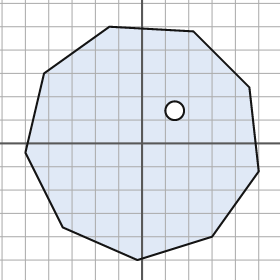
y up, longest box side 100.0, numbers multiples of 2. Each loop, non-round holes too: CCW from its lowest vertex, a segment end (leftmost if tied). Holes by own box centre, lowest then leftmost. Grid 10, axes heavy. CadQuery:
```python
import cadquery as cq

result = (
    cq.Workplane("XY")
    .moveTo(-2.0, -50.0)
    .lineTo(30.0, -40.0)
    .lineTo(50.0, -12.0)
    .lineTo(46.0, 24.0)
    .lineTo(22.0, 48.0)
    .lineTo(-14.0, 50.0)
    .lineTo(-42.0, 30.0)
    .lineTo(-50.0, -4.0)
    .lineTo(-34.0, -36.0)
    .close()
    .moveTo(14.0, 14.0)
    .circle(4.0)
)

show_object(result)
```